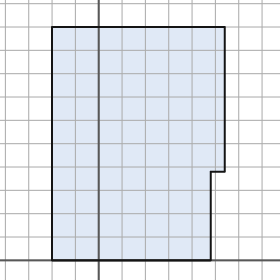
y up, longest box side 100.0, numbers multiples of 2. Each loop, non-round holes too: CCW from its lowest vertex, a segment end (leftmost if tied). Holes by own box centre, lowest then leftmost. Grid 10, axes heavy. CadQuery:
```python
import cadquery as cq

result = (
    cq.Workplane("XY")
    .moveTo(-20.0, 0.0)
    .lineTo(48.0, 0.0)
    .lineTo(48.0, 38.0)
    .lineTo(54.0, 38.0)
    .lineTo(54.0, 100.0)
    .lineTo(-20.0, 100.0)
    .close()
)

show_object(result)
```